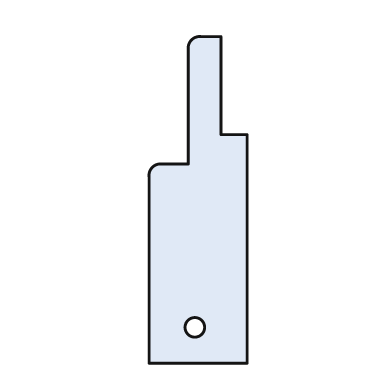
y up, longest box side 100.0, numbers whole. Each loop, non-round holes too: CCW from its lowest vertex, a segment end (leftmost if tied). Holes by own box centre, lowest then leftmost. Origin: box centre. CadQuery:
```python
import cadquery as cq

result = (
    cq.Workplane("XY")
    .moveTo(-15.0, -50.0)
    .lineTo(15.0, -50.0)
    .lineTo(15.0, 20.0)
    .lineTo(7.0, 20.0)
    .lineTo(7.0, 50.0)
    .lineTo(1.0, 50.0)
    .threePointArc((-2.0, 49.0), (-3.0, 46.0))
    .lineTo(-3.0, 11.0)
    .lineTo(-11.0, 11.0)
    .threePointArc((-14.0, 10.0), (-15.0, 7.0))
    .close()
    .moveTo(-1.0, -39.0)
    .circle(3.0)
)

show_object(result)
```